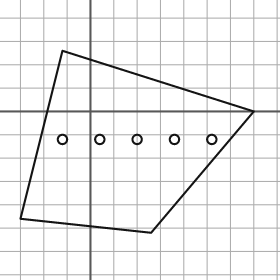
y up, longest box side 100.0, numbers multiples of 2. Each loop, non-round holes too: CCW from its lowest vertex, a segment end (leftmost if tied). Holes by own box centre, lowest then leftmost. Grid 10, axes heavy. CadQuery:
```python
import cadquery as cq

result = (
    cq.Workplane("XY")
    .moveTo(26.0, -52.0)
    .lineTo(70.0, 0.0)
    .lineTo(-12.0, 26.0)
    .lineTo(-30.0, -46.0)
    .close()
    .moveTo(-12.0, -12.0)
    .circle(2.0)
    .moveTo(4.0, -12.0)
    .circle(2.0)
    .moveTo(20.0, -12.0)
    .circle(2.0)
    .moveTo(36.0, -12.0)
    .circle(2.0)
    .moveTo(52.0, -12.0)
    .circle(2.0)
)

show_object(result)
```